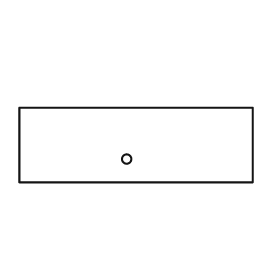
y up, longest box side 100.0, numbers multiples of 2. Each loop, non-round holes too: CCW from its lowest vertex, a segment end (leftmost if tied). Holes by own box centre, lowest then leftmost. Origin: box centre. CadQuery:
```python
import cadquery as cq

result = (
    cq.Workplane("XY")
    .moveTo(-50.0, -16.0)
    .lineTo(50.0, -16.0)
    .lineTo(50.0, 16.0)
    .lineTo(-50.0, 16.0)
    .close()
    .moveTo(-4.0, -6.0)
    .circle(2.0)
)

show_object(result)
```